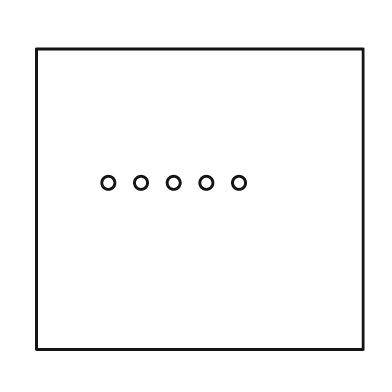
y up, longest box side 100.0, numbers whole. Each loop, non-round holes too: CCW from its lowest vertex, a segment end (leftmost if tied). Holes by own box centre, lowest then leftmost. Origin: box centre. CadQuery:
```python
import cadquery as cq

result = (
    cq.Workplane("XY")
    .moveTo(-50.0, -46.0)
    .lineTo(50.0, -46.0)
    .lineTo(50.0, 46.0)
    .lineTo(-50.0, 46.0)
    .close()
    .moveTo(-28.0, 5.0)
    .circle(2.0)
    .moveTo(-18.0, 5.0)
    .circle(2.0)
    .moveTo(-8.0, 5.0)
    .circle(2.0)
    .moveTo(2.0, 5.0)
    .circle(2.0)
    .moveTo(12.0, 5.0)
    .circle(2.0)
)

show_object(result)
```